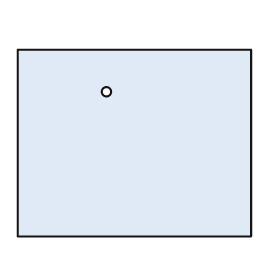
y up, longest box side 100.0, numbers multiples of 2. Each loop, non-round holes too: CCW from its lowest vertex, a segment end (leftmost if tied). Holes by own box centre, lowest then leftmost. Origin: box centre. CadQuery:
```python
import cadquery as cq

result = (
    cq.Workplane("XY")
    .moveTo(-50.0, -40.0)
    .lineTo(50.0, -40.0)
    .lineTo(50.0, 40.0)
    .lineTo(-50.0, 40.0)
    .close()
    .moveTo(-12.0, 22.0)
    .circle(2.0)
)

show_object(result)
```